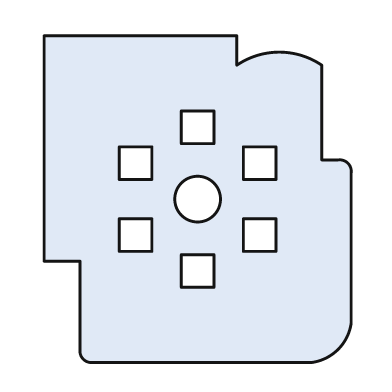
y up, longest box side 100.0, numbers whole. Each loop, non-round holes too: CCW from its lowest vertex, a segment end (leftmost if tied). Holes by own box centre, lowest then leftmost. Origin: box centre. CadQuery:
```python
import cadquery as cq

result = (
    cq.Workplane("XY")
    .moveTo(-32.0, -50.0)
    .lineTo(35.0, -50.0)
    .threePointArc((43.0, -46.0), (47.0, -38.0))
    .lineTo(47.0, 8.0)
    .threePointArc((46.0, 11.0), (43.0, 12.0))
    .lineTo(38.0, 12.0)
    .lineTo(38.0, 41.0)
    .threePointArc((25.0, 45.0), (12.0, 41.0))
    .lineTo(12.0, 50.0)
    .lineTo(-47.0, 50.0)
    .lineTo(-47.0, -19.0)
    .lineTo(-36.0, -19.0)
    .lineTo(-36.0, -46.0)
    .threePointArc((-35.0, -49.0), (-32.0, -50.0))
    .close()
    .moveTo(-5.0, -27.0)
    .lineTo(5.0, -27.0)
    .lineTo(5.0, -17.0)
    .lineTo(-5.0, -17.0)
    .close()
    .moveTo(-24.0, -16.0)
    .lineTo(-14.0, -16.0)
    .lineTo(-14.0, -6.0)
    .lineTo(-24.0, -6.0)
    .close()
    .moveTo(14.0, -16.0)
    .lineTo(24.0, -16.0)
    .lineTo(24.0, -6.0)
    .lineTo(14.0, -6.0)
    .close()
    .moveTo(0.0, 0.0)
    .circle(7.0)
    .moveTo(-24.0, 6.0)
    .lineTo(-14.0, 6.0)
    .lineTo(-14.0, 16.0)
    .lineTo(-24.0, 16.0)
    .close()
    .moveTo(14.0, 6.0)
    .lineTo(24.0, 6.0)
    .lineTo(24.0, 16.0)
    .lineTo(14.0, 16.0)
    .close()
    .moveTo(-5.0, 17.0)
    .lineTo(5.0, 17.0)
    .lineTo(5.0, 27.0)
    .lineTo(-5.0, 27.0)
    .close()
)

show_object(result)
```